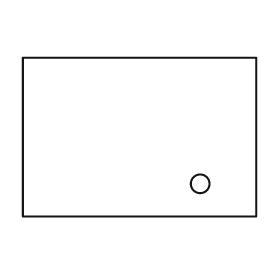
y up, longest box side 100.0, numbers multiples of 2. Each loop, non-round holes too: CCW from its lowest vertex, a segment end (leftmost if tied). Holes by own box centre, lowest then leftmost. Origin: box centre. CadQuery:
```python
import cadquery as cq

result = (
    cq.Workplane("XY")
    .moveTo(-50.0, -34.0)
    .lineTo(50.0, -34.0)
    .lineTo(50.0, 34.0)
    .lineTo(-50.0, 34.0)
    .close()
    .moveTo(26.0, -20.0)
    .circle(4.0)
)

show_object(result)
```